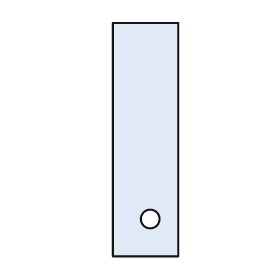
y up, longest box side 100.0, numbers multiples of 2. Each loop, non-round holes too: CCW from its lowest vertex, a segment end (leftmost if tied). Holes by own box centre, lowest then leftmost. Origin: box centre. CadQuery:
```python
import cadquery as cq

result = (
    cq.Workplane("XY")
    .moveTo(-14.0, -50.0)
    .lineTo(14.0, -50.0)
    .lineTo(14.0, 50.0)
    .lineTo(-14.0, 50.0)
    .close()
    .moveTo(2.0, -34.0)
    .circle(4.0)
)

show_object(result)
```